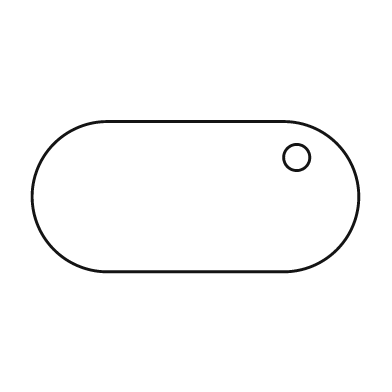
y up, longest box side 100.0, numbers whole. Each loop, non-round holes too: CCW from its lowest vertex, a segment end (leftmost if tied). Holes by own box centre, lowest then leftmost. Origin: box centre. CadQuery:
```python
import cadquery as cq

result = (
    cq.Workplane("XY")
    .moveTo(-27.0, -23.0)
    .lineTo(27.0, -23.0)
    .threePointArc((50.0, 0.0), (27.0, 23.0))
    .lineTo(-27.0, 23.0)
    .threePointArc((-50.0, 0.0), (-27.0, -23.0))
    .close()
    .moveTo(31.0, 12.0)
    .circle(4.0)
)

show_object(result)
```